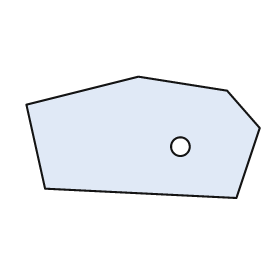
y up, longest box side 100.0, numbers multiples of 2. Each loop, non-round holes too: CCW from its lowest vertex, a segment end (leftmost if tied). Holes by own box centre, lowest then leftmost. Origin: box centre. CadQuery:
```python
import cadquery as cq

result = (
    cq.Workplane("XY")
    .moveTo(40.0, -26.0)
    .lineTo(50.0, 4.0)
    .lineTo(36.0, 20.0)
    .lineTo(-2.0, 26.0)
    .lineTo(-50.0, 14.0)
    .lineTo(-42.0, -22.0)
    .close()
    .moveTo(16.0, -4.0)
    .circle(4.0)
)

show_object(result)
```